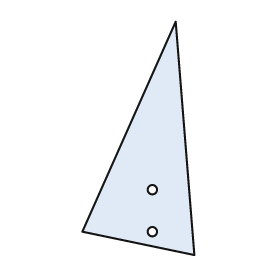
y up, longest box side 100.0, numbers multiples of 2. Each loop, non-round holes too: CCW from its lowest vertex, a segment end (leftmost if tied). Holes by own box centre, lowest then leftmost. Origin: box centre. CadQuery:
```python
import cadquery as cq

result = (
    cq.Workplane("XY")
    .moveTo(24.0, -50.0)
    .lineTo(16.0, 50.0)
    .lineTo(-24.0, -40.0)
    .close()
    .moveTo(6.0, -40.0)
    .circle(2.0)
    .moveTo(6.0, -22.0)
    .circle(2.0)
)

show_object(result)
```